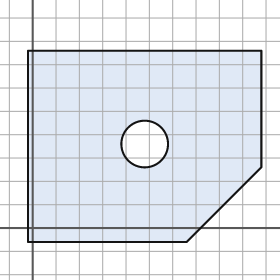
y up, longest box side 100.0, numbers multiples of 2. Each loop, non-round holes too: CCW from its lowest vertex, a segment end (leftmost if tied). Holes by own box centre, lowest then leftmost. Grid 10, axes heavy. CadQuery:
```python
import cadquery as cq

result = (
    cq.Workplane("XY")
    .moveTo(-2.0, -6.0)
    .lineTo(66.0, -6.0)
    .lineTo(98.0, 26.0)
    .lineTo(98.0, 76.0)
    .lineTo(-2.0, 76.0)
    .close()
    .moveTo(48.0, 36.0)
    .circle(10.0)
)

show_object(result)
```